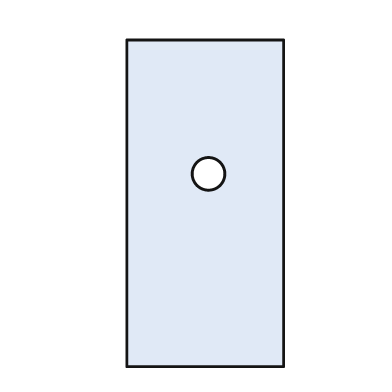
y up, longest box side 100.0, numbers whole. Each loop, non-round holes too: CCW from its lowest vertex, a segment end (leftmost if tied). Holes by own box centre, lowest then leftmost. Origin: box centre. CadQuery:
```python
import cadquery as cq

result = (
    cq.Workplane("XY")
    .moveTo(-24.0, -50.0)
    .lineTo(24.0, -50.0)
    .lineTo(24.0, 50.0)
    .lineTo(-24.0, 50.0)
    .close()
    .moveTo(1.0, 9.0)
    .circle(5.0)
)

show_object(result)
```